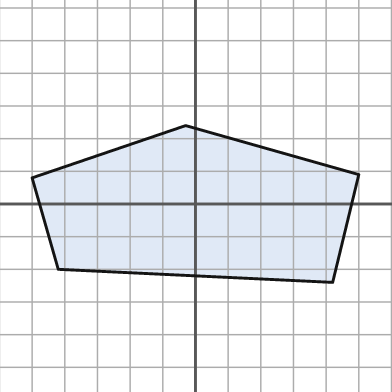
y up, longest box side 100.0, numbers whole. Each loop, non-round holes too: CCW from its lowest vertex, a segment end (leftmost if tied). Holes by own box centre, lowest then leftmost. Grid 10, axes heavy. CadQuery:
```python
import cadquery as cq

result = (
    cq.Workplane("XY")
    .moveTo(42.0, -24.0)
    .lineTo(50.0, 9.0)
    .lineTo(-3.0, 24.0)
    .lineTo(-50.0, 8.0)
    .lineTo(-42.0, -20.0)
    .close()
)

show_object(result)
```